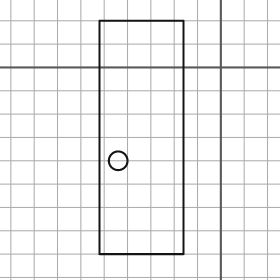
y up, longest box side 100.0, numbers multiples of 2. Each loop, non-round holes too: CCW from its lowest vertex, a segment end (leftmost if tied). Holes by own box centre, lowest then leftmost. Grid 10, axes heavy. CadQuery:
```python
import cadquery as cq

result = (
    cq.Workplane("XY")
    .moveTo(-52.0, -80.0)
    .lineTo(-16.0, -80.0)
    .lineTo(-16.0, 20.0)
    .lineTo(-52.0, 20.0)
    .close()
    .moveTo(-44.0, -40.0)
    .circle(4.0)
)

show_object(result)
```